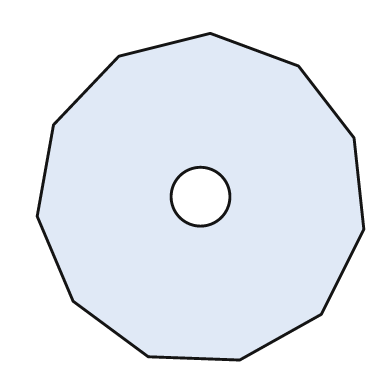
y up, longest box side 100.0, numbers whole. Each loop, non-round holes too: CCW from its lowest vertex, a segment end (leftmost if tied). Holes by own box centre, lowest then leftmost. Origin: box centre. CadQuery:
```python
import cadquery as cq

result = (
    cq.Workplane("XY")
    .moveTo(12.0, -50.0)
    .lineTo(37.0, -36.0)
    .lineTo(50.0, -10.0)
    .lineTo(47.0, 18.0)
    .lineTo(30.0, 40.0)
    .lineTo(3.0, 50.0)
    .lineTo(-25.0, 43.0)
    .lineTo(-45.0, 22.0)
    .lineTo(-50.0, -6.0)
    .lineTo(-39.0, -32.0)
    .lineTo(-16.0, -49.0)
    .close()
    .moveTo(0.0, 0.0)
    .circle(9.0)
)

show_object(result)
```